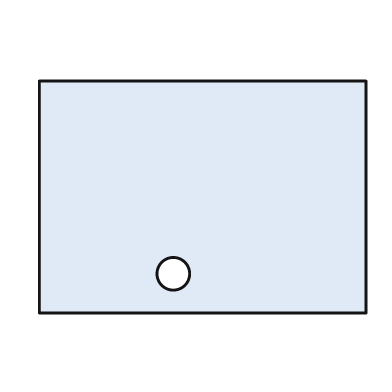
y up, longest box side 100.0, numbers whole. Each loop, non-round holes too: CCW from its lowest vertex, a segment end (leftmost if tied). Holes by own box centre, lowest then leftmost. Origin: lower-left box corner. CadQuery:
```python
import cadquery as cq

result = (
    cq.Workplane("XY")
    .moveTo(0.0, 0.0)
    .lineTo(100.0, 0.0)
    .lineTo(100.0, 71.0)
    .lineTo(0.0, 71.0)
    .close()
    .moveTo(41.0, 12.0)
    .circle(5.0)
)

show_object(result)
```